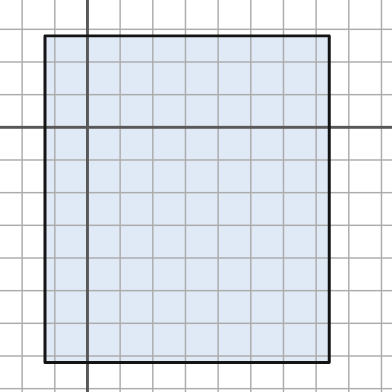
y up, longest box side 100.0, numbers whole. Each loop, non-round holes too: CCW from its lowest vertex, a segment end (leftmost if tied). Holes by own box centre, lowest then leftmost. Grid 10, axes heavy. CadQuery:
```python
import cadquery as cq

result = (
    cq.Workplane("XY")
    .moveTo(-13.0, -72.0)
    .lineTo(74.0, -72.0)
    .lineTo(74.0, 28.0)
    .lineTo(-13.0, 28.0)
    .close()
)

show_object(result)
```